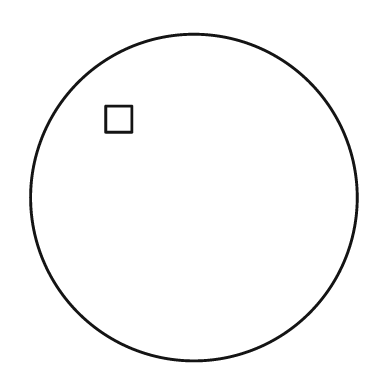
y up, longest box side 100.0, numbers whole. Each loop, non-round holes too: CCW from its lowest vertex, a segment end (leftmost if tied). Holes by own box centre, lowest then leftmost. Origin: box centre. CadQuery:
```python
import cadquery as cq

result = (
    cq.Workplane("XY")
    .moveTo(0.0, 0.0)
    .circle(50.0)
    .moveTo(-27.0, 20.0)
    .lineTo(-19.0, 20.0)
    .lineTo(-19.0, 28.0)
    .lineTo(-27.0, 28.0)
    .close()
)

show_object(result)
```